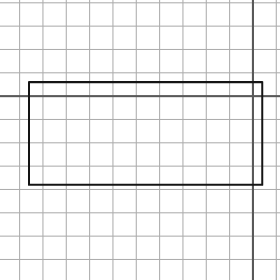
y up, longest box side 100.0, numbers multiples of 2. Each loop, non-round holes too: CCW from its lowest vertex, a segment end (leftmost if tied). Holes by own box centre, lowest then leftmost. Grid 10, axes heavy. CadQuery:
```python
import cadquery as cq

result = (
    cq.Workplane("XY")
    .moveTo(-96.0, -38.0)
    .lineTo(4.0, -38.0)
    .lineTo(4.0, 6.0)
    .lineTo(-96.0, 6.0)
    .close()
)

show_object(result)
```